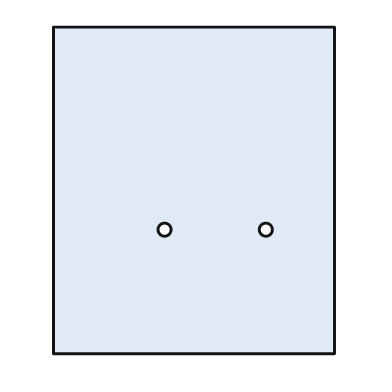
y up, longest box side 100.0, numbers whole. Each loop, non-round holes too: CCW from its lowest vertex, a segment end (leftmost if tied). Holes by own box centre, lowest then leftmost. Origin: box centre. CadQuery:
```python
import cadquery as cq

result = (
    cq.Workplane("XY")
    .moveTo(-43.0, -50.0)
    .lineTo(43.0, -50.0)
    .lineTo(43.0, 50.0)
    .lineTo(-43.0, 50.0)
    .close()
    .moveTo(-9.0, -12.0)
    .circle(2.0)
    .moveTo(22.0, -12.0)
    .circle(2.0)
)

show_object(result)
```